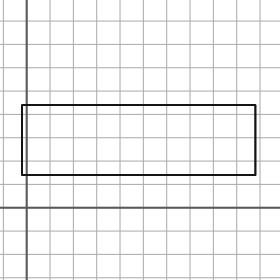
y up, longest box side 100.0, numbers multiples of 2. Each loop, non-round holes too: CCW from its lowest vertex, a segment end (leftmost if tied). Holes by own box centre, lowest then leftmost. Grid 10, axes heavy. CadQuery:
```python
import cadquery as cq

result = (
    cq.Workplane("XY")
    .moveTo(-2.0, 14.0)
    .lineTo(98.0, 14.0)
    .lineTo(98.0, 44.0)
    .lineTo(-2.0, 44.0)
    .close()
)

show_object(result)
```